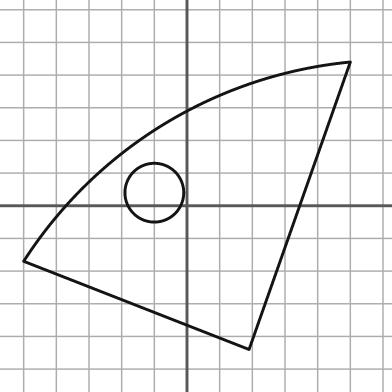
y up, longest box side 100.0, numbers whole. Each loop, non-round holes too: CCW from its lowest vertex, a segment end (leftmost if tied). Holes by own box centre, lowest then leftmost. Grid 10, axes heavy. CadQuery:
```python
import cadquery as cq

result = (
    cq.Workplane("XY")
    .moveTo(19.0, -44.0)
    .lineTo(50.0, 44.0)
    .threePointArc((-7.0, 25.0), (-50.0, -17.0))
    .close()
    .moveTo(-10.0, 4.0)
    .circle(9.0)
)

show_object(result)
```